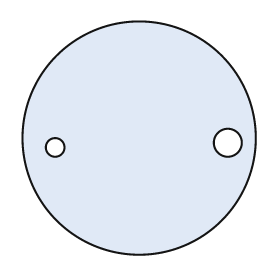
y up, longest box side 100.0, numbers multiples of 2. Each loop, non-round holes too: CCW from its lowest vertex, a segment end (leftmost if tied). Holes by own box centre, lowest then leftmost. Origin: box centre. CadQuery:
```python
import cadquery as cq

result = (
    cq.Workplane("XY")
    .moveTo(0.0, 0.0)
    .circle(50.0)
    .moveTo(-36.0, -4.0)
    .circle(4.0)
    .moveTo(38.0, -2.0)
    .circle(6.0)
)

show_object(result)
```